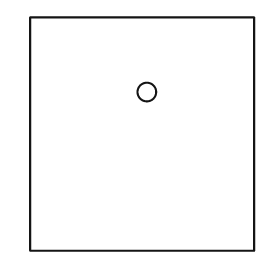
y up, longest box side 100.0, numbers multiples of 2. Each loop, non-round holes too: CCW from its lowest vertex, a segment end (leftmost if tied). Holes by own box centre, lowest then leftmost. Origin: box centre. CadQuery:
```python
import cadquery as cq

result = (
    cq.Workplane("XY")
    .moveTo(-48.0, -50.0)
    .lineTo(48.0, -50.0)
    .lineTo(48.0, 50.0)
    .lineTo(-48.0, 50.0)
    .close()
    .moveTo(2.0, 18.0)
    .circle(4.0)
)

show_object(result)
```